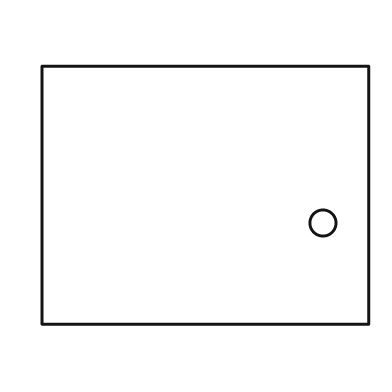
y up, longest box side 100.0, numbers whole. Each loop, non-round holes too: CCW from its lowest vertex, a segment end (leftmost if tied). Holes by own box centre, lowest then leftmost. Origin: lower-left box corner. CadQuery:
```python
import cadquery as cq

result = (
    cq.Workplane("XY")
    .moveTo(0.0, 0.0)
    .lineTo(100.0, 0.0)
    .lineTo(100.0, 79.0)
    .lineTo(0.0, 79.0)
    .close()
    .moveTo(86.0, 31.0)
    .circle(4.0)
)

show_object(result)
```